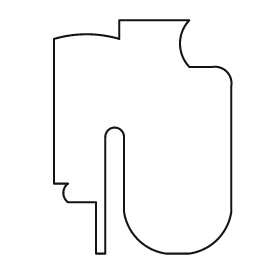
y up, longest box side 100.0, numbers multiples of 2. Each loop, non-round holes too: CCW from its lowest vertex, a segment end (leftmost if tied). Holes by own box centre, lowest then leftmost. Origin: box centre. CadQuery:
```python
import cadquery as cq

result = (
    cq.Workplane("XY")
    .moveTo(-20.0, -50.0)
    .lineTo(-16.0, -50.0)
    .lineTo(-16.0, 0.0)
    .threePointArc((-12.0, 4.0), (-8.0, 0.0))
    .lineTo(-8.0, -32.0)
    .threePointArc((-2.0, -44.0), (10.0, -50.0))
    .lineTo(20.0, -50.0)
    .threePointArc((32.0, -44.0), (38.0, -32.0))
    .lineTo(38.0, 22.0)
    .threePointArc((36.0, 28.0), (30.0, 30.0))
    .lineTo(20.0, 30.0)
    .threePointArc((16.0, 40.0), (20.0, 50.0))
    .lineTo(-10.0, 50.0)
    .lineTo(-10.0, 42.0)
    .threePointArc((-24.0, 44.0), (-38.0, 42.0))
    .lineTo(-38.0, -20.0)
    .lineTo(-32.0, -20.0)
    .threePointArc((-34.0, -24.0), (-32.0, -28.0))
    .lineTo(-20.0, -28.0)
    .close()
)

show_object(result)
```